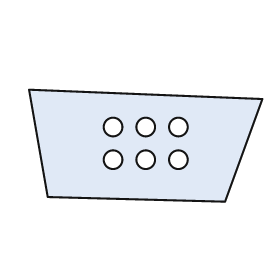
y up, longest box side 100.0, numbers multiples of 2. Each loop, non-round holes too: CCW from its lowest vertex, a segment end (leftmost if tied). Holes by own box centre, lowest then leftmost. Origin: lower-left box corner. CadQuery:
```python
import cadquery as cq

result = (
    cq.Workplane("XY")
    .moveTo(84.0, 0.0)
    .lineTo(100.0, 44.0)
    .lineTo(0.0, 48.0)
    .lineTo(8.0, 2.0)
    .close()
    .moveTo(36.0, 18.0)
    .circle(4.0)
    .moveTo(50.0, 18.0)
    .circle(4.0)
    .moveTo(64.0, 18.0)
    .circle(4.0)
    .moveTo(36.0, 32.0)
    .circle(4.0)
    .moveTo(50.0, 32.0)
    .circle(4.0)
    .moveTo(64.0, 32.0)
    .circle(4.0)
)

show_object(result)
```